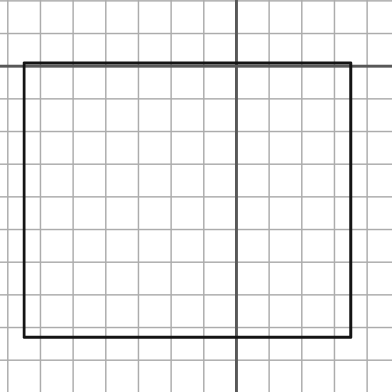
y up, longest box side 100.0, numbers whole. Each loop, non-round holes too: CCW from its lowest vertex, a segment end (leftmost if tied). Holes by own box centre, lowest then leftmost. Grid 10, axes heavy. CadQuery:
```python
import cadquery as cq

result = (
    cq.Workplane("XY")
    .moveTo(-65.0, -83.0)
    .lineTo(35.0, -83.0)
    .lineTo(35.0, 1.0)
    .lineTo(-65.0, 1.0)
    .close()
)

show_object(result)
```